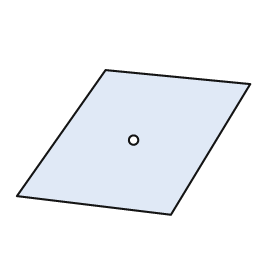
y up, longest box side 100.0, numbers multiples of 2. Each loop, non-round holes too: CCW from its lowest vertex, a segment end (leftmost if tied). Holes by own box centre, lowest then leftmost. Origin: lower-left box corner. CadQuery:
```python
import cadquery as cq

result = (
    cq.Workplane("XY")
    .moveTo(66.0, 0.0)
    .lineTo(100.0, 56.0)
    .lineTo(38.0, 62.0)
    .lineTo(0.0, 8.0)
    .close()
    .moveTo(50.0, 32.0)
    .circle(2.0)
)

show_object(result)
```